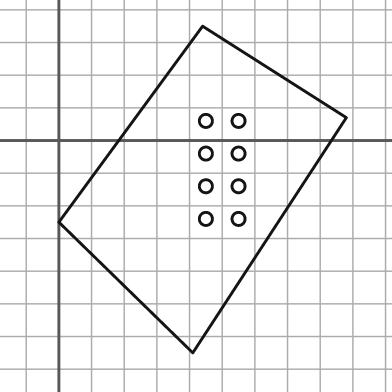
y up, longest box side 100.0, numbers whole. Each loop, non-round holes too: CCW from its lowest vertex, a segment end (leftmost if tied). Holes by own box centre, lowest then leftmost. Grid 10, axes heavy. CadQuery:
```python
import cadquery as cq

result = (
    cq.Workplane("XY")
    .moveTo(41.0, -65.0)
    .lineTo(88.0, 7.0)
    .lineTo(44.0, 35.0)
    .lineTo(0.0, -25.0)
    .close()
    .moveTo(45.0, -24.0)
    .circle(2.0)
    .moveTo(55.0, -24.0)
    .circle(2.0)
    .moveTo(45.0, -14.0)
    .circle(2.0)
    .moveTo(55.0, -14.0)
    .circle(2.0)
    .moveTo(45.0, -4.0)
    .circle(2.0)
    .moveTo(55.0, -4.0)
    .circle(2.0)
    .moveTo(45.0, 6.0)
    .circle(2.0)
    .moveTo(55.0, 6.0)
    .circle(2.0)
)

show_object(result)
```